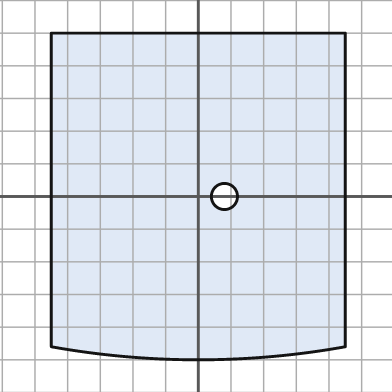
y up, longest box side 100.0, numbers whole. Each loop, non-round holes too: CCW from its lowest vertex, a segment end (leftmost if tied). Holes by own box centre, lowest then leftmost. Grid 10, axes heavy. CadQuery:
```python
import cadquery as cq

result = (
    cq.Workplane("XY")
    .moveTo(-45.0, -46.0)
    .threePointArc((0.0, -50.0), (45.0, -46.0))
    .lineTo(45.0, 50.0)
    .lineTo(-45.0, 50.0)
    .close()
    .moveTo(8.0, 0.0)
    .circle(4.0)
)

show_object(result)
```